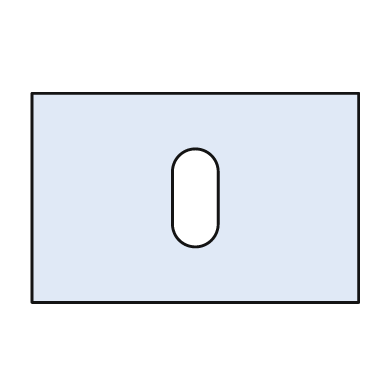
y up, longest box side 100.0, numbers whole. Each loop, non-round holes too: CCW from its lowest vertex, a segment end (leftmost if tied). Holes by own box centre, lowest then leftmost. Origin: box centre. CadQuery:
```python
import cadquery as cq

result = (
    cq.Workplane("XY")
    .moveTo(-50.0, -32.0)
    .lineTo(50.0, -32.0)
    .lineTo(50.0, 32.0)
    .lineTo(-50.0, 32.0)
    .close()
    .moveTo(-7.0, -8.0)
    .threePointArc((0.0, -15.0), (7.0, -8.0))
    .lineTo(7.0, 8.0)
    .threePointArc((0.0, 15.0), (-7.0, 8.0))
    .close()
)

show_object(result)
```